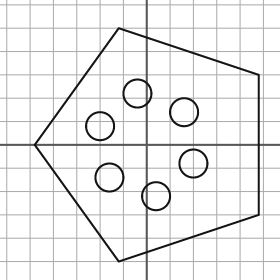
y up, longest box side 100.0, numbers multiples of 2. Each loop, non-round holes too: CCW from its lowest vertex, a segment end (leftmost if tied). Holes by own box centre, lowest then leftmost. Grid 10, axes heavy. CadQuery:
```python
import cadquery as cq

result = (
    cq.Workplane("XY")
    .moveTo(-12.0, -50.0)
    .lineTo(48.0, -30.0)
    .lineTo(48.0, 30.0)
    .lineTo(-12.0, 50.0)
    .lineTo(-48.0, 0.0)
    .close()
    .moveTo(4.0, -22.0)
    .circle(6.0)
    .moveTo(-16.0, -14.0)
    .circle(6.0)
    .moveTo(20.0, -8.0)
    .circle(6.0)
    .moveTo(-20.0, 8.0)
    .circle(6.0)
    .moveTo(16.0, 14.0)
    .circle(6.0)
    .moveTo(-4.0, 22.0)
    .circle(6.0)
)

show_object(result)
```